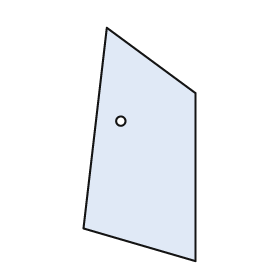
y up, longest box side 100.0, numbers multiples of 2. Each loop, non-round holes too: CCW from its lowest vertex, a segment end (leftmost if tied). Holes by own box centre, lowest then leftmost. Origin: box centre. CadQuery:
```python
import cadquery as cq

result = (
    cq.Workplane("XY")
    .moveTo(24.0, -50.0)
    .lineTo(24.0, 22.0)
    .lineTo(-14.0, 50.0)
    .lineTo(-24.0, -36.0)
    .close()
    .moveTo(-8.0, 10.0)
    .circle(2.0)
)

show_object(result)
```